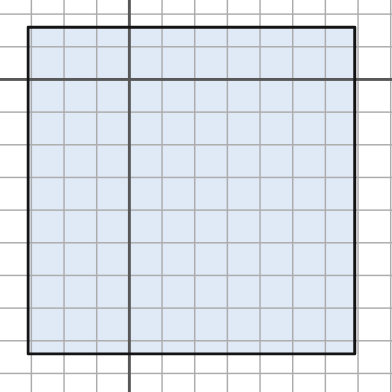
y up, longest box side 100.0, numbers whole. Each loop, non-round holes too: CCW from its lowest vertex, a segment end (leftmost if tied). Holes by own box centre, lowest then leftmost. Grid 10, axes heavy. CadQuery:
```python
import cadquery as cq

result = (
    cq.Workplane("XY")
    .moveTo(-31.0, -84.0)
    .lineTo(69.0, -84.0)
    .lineTo(69.0, 16.0)
    .lineTo(-31.0, 16.0)
    .close()
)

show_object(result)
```